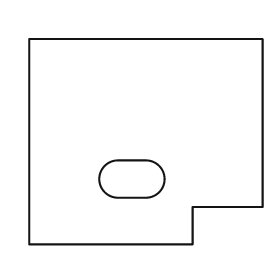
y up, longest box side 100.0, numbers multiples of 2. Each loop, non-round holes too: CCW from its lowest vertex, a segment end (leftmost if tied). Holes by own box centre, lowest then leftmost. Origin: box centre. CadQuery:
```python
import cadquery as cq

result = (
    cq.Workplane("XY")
    .moveTo(-50.0, -44.0)
    .lineTo(20.0, -44.0)
    .lineTo(20.0, -28.0)
    .lineTo(50.0, -28.0)
    .lineTo(50.0, 44.0)
    .lineTo(-50.0, 44.0)
    .close()
    .moveTo(-12.0, -24.0)
    .lineTo(0.0, -24.0)
    .threePointArc((8.0, -16.0), (0.0, -8.0))
    .lineTo(-12.0, -8.0)
    .threePointArc((-20.0, -16.0), (-12.0, -24.0))
    .close()
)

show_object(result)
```